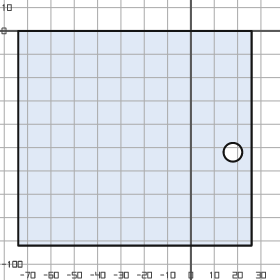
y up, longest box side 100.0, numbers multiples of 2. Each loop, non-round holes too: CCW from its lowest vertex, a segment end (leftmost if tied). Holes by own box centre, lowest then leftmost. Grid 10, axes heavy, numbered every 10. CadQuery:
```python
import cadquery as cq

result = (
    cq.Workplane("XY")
    .moveTo(-74.0, -92.0)
    .lineTo(26.0, -92.0)
    .lineTo(26.0, 0.0)
    .lineTo(-74.0, 0.0)
    .close()
    .moveTo(18.0, -52.0)
    .circle(4.0)
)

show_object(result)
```